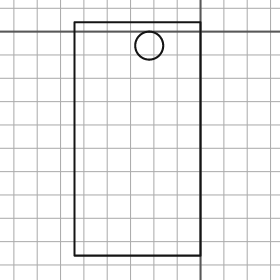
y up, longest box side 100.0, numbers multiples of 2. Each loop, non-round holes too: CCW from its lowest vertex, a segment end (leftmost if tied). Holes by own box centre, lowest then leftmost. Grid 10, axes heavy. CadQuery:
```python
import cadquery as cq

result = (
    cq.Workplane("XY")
    .moveTo(-54.0, -96.0)
    .lineTo(0.0, -96.0)
    .lineTo(0.0, 4.0)
    .lineTo(-54.0, 4.0)
    .close()
    .moveTo(-22.0, -6.0)
    .circle(6.0)
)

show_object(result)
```